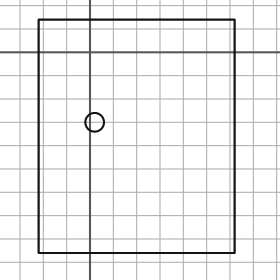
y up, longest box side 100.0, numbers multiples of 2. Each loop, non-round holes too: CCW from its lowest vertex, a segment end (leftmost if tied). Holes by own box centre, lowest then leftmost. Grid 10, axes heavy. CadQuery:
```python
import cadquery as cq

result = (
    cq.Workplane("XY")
    .moveTo(-22.0, -86.0)
    .lineTo(62.0, -86.0)
    .lineTo(62.0, 14.0)
    .lineTo(-22.0, 14.0)
    .close()
    .moveTo(2.0, -30.0)
    .circle(4.0)
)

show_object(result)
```